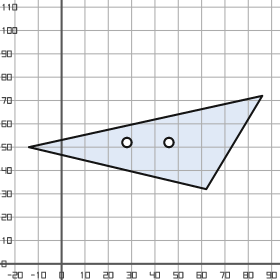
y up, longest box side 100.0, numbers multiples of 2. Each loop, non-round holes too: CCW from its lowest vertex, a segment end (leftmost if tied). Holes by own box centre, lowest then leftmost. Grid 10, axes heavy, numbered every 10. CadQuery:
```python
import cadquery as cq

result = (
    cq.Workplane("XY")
    .moveTo(62.0, 32.0)
    .lineTo(86.0, 72.0)
    .lineTo(-14.0, 50.0)
    .close()
    .moveTo(28.0, 52.0)
    .circle(2.0)
    .moveTo(46.0, 52.0)
    .circle(2.0)
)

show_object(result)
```